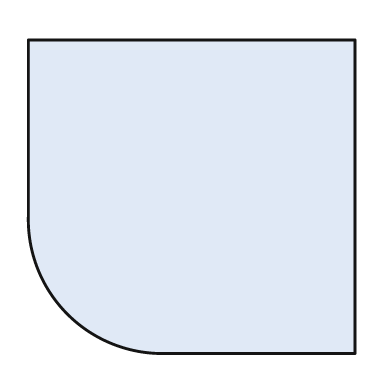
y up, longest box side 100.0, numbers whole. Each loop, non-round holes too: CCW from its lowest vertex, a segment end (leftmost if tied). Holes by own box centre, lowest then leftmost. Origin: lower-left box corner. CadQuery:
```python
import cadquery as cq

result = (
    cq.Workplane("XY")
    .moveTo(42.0, 0.0)
    .lineTo(100.0, 0.0)
    .lineTo(100.0, 96.0)
    .lineTo(0.0, 96.0)
    .lineTo(0.0, 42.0)
    .threePointArc((12.0, 12.0), (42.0, 0.0))
    .close()
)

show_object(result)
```